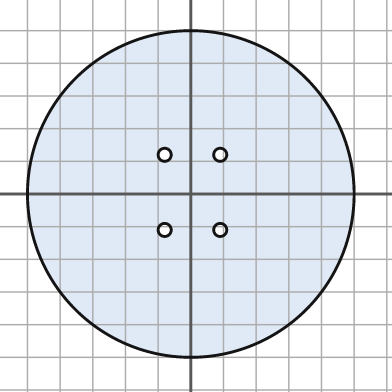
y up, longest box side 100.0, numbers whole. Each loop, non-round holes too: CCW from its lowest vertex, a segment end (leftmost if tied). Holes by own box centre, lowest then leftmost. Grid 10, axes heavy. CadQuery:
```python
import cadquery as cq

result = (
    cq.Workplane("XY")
    .moveTo(0.0, 0.0)
    .circle(50.0)
    .moveTo(-8.0, -11.0)
    .circle(2.0)
    .moveTo(9.0, -11.0)
    .circle(2.0)
    .moveTo(-8.0, 12.0)
    .circle(2.0)
    .moveTo(9.0, 12.0)
    .circle(2.0)
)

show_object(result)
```